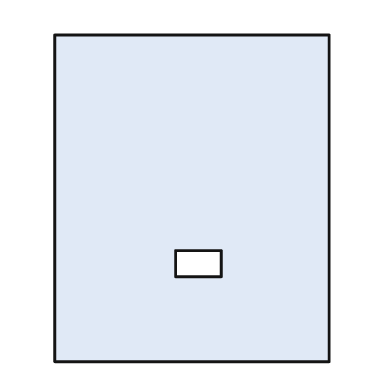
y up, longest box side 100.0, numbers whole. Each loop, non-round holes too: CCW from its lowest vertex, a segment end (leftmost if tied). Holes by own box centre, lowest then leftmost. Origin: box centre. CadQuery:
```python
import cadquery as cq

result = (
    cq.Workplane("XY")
    .moveTo(-42.0, -50.0)
    .lineTo(42.0, -50.0)
    .lineTo(42.0, 50.0)
    .lineTo(-42.0, 50.0)
    .close()
    .moveTo(-5.0, -24.0)
    .lineTo(9.0, -24.0)
    .lineTo(9.0, -16.0)
    .lineTo(-5.0, -16.0)
    .close()
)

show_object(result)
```